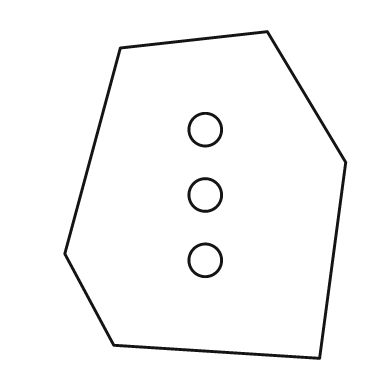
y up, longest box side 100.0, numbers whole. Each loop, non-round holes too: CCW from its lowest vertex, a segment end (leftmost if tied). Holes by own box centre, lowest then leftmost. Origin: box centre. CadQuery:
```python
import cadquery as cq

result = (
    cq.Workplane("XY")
    .moveTo(35.0, -50.0)
    .lineTo(43.0, 10.0)
    .lineTo(19.0, 50.0)
    .lineTo(-26.0, 45.0)
    .lineTo(-43.0, -18.0)
    .lineTo(-28.0, -46.0)
    .close()
    .moveTo(0.0, -20.0)
    .circle(5.0)
    .moveTo(0.0, 0.0)
    .circle(5.0)
    .moveTo(0.0, 20.0)
    .circle(5.0)
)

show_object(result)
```